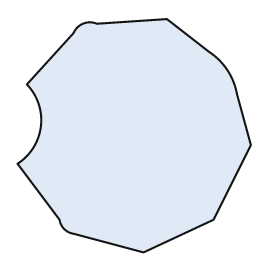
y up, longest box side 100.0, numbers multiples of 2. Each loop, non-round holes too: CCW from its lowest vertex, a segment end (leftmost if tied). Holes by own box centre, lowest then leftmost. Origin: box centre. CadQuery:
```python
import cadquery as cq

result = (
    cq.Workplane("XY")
    .moveTo(4.0, -50.0)
    .lineTo(34.0, -36.0)
    .lineTo(50.0, -4.0)
    .lineTo(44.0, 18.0)
    .threePointArc((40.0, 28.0), (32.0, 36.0))
    .lineTo(14.0, 50.0)
    .lineTo(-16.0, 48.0)
    .threePointArc((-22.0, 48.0), (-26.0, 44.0))
    .lineTo(-46.0, 22.0)
    .threePointArc((-40.0, 4.0), (-50.0, -12.0))
    .lineTo(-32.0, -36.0)
    .threePointArc((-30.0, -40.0), (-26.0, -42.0))
    .close()
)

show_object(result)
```